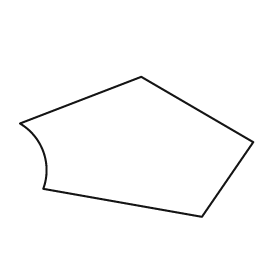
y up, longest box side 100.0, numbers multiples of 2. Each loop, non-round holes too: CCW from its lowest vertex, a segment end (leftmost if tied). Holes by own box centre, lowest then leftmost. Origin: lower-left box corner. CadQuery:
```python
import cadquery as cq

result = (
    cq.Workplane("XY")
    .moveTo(78.0, 0.0)
    .lineTo(100.0, 32.0)
    .lineTo(52.0, 60.0)
    .lineTo(0.0, 40.0)
    .threePointArc((10.0, 28.0), (10.0, 12.0))
    .close()
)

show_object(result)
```